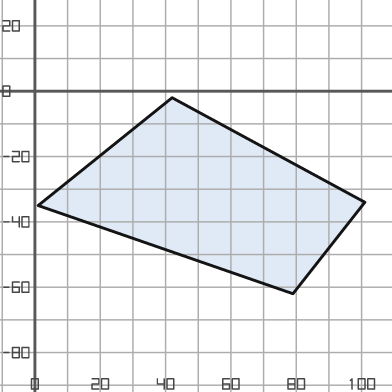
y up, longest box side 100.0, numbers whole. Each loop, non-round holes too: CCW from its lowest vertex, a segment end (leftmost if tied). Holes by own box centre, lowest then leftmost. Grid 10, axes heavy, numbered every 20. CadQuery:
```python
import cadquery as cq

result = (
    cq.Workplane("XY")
    .moveTo(79.0, -62.0)
    .lineTo(101.0, -34.0)
    .lineTo(42.0, -2.0)
    .lineTo(1.0, -35.0)
    .close()
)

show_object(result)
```